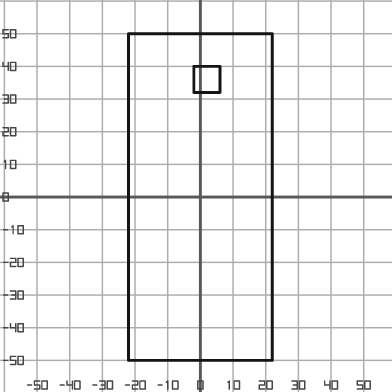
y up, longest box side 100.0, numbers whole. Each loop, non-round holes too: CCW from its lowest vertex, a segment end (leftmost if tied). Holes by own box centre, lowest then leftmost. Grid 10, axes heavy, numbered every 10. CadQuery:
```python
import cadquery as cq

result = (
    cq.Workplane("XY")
    .moveTo(-22.0, -50.0)
    .lineTo(22.0, -50.0)
    .lineTo(22.0, 50.0)
    .lineTo(-22.0, 50.0)
    .close()
    .moveTo(-2.0, 32.0)
    .lineTo(6.0, 32.0)
    .lineTo(6.0, 40.0)
    .lineTo(-2.0, 40.0)
    .close()
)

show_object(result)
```